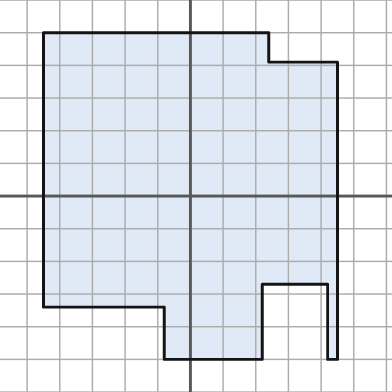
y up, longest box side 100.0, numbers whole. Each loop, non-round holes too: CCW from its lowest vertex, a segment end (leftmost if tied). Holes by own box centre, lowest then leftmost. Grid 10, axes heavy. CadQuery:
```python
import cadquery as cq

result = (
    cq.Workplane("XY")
    .moveTo(-8.0, -50.0)
    .lineTo(22.0, -50.0)
    .lineTo(22.0, -27.0)
    .lineTo(42.0, -27.0)
    .lineTo(42.0, -50.0)
    .lineTo(45.0, -50.0)
    .lineTo(45.0, 41.0)
    .lineTo(24.0, 41.0)
    .lineTo(24.0, 50.0)
    .lineTo(-45.0, 50.0)
    .lineTo(-45.0, -34.0)
    .lineTo(-8.0, -34.0)
    .close()
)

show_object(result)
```